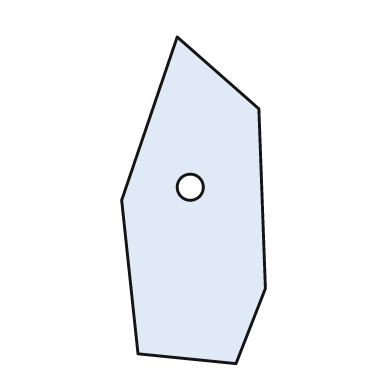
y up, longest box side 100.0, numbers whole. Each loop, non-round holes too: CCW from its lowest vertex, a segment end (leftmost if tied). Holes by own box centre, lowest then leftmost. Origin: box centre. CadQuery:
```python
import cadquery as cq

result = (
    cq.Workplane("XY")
    .moveTo(13.0, -50.0)
    .lineTo(22.0, -27.0)
    .lineTo(20.0, 28.0)
    .lineTo(-5.0, 50.0)
    .lineTo(-22.0, 0.0)
    .lineTo(-17.0, -47.0)
    .close()
    .moveTo(-1.0, 4.0)
    .circle(4.0)
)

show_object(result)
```